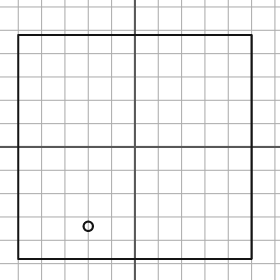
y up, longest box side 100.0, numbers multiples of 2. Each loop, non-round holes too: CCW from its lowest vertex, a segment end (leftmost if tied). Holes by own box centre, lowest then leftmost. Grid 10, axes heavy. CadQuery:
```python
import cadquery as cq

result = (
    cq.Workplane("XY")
    .moveTo(-50.0, -48.0)
    .lineTo(50.0, -48.0)
    .lineTo(50.0, 48.0)
    .lineTo(-50.0, 48.0)
    .close()
    .moveTo(-20.0, -34.0)
    .circle(2.0)
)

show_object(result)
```